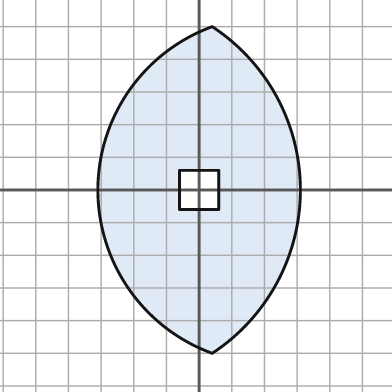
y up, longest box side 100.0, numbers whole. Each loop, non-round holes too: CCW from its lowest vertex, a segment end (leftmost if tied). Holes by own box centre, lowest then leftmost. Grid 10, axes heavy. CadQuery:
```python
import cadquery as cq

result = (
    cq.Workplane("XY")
    .moveTo(4.0, -50.0)
    .threePointArc((31.0, 0.0), (4.0, 50.0))
    .threePointArc((-31.0, 0.0), (4.0, -50.0))
    .close()
    .moveTo(-6.0, -6.0)
    .lineTo(6.0, -6.0)
    .lineTo(6.0, 6.0)
    .lineTo(-6.0, 6.0)
    .close()
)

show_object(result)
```